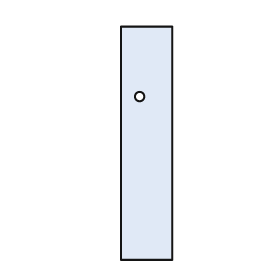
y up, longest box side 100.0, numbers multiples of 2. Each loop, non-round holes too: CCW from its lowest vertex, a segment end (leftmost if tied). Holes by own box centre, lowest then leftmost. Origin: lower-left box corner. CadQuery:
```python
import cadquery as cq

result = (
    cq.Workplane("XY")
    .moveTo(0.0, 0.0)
    .lineTo(22.0, 0.0)
    .lineTo(22.0, 100.0)
    .lineTo(0.0, 100.0)
    .close()
    .moveTo(8.0, 70.0)
    .circle(2.0)
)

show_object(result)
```